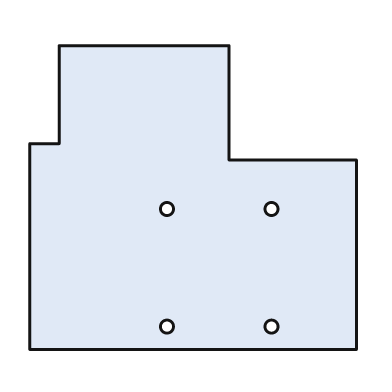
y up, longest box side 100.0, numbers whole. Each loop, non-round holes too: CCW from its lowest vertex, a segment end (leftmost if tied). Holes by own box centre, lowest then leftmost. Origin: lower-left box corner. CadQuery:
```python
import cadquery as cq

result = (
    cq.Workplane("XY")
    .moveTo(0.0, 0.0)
    .lineTo(100.0, 0.0)
    .lineTo(100.0, 58.0)
    .lineTo(61.0, 58.0)
    .lineTo(61.0, 93.0)
    .lineTo(9.0, 93.0)
    .lineTo(9.0, 63.0)
    .lineTo(0.0, 63.0)
    .close()
    .moveTo(42.0, 7.0)
    .circle(2.0)
    .moveTo(74.0, 7.0)
    .circle(2.0)
    .moveTo(42.0, 43.0)
    .circle(2.0)
    .moveTo(74.0, 43.0)
    .circle(2.0)
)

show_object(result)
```